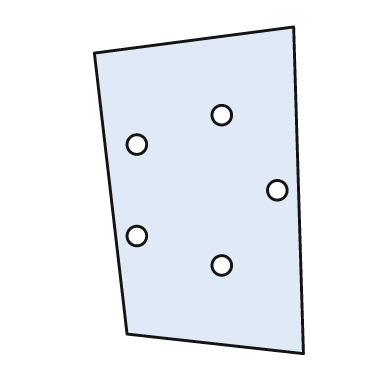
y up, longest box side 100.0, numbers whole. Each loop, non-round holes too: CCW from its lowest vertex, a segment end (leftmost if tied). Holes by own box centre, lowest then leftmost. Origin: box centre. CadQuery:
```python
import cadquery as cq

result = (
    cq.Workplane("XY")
    .moveTo(32.0, -50.0)
    .lineTo(29.0, 50.0)
    .lineTo(-32.0, 42.0)
    .lineTo(-22.0, -44.0)
    .close()
    .moveTo(7.0, -23.0)
    .circle(3.0)
    .moveTo(-19.0, -14.0)
    .circle(3.0)
    .moveTo(24.0, 0.0)
    .circle(3.0)
    .moveTo(-19.0, 14.0)
    .circle(3.0)
    .moveTo(7.0, 23.0)
    .circle(3.0)
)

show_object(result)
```